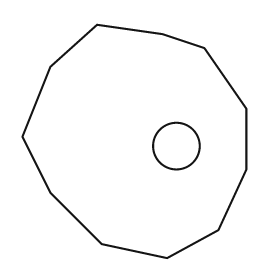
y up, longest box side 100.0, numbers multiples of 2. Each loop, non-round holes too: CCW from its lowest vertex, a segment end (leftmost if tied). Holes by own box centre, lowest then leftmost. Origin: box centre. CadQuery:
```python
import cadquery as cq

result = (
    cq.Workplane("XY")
    .moveTo(14.0, -50.0)
    .lineTo(36.0, -38.0)
    .lineTo(48.0, -12.0)
    .lineTo(48.0, 14.0)
    .lineTo(30.0, 40.0)
    .lineTo(12.0, 46.0)
    .lineTo(-16.0, 50.0)
    .lineTo(-36.0, 32.0)
    .lineTo(-48.0, 2.0)
    .lineTo(-36.0, -22.0)
    .lineTo(-14.0, -44.0)
    .close()
    .moveTo(18.0, -2.0)
    .circle(10.0)
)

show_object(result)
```